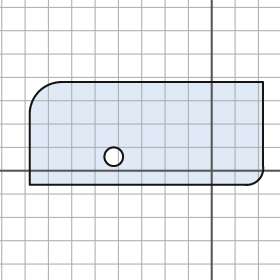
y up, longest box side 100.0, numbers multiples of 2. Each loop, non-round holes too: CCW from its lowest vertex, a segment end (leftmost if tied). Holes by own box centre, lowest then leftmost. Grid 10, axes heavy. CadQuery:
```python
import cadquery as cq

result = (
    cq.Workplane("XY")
    .moveTo(-78.0, -6.0)
    .lineTo(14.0, -6.0)
    .threePointArc((20.0, -4.0), (22.0, 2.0))
    .lineTo(22.0, 38.0)
    .lineTo(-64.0, 38.0)
    .threePointArc((-74.0, 34.0), (-78.0, 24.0))
    .close()
    .moveTo(-42.0, 6.0)
    .circle(4.0)
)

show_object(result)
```